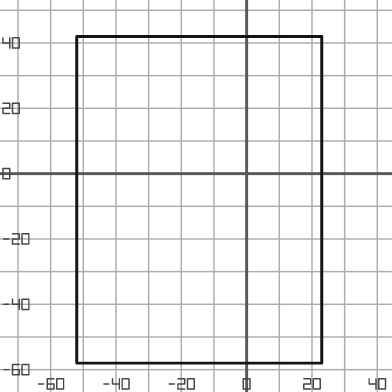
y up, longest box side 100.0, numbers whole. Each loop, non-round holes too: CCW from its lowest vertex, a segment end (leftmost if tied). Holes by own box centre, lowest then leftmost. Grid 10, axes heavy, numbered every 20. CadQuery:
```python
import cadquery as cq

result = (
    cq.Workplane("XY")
    .moveTo(-52.0, -58.0)
    .lineTo(23.0, -58.0)
    .lineTo(23.0, 42.0)
    .lineTo(-52.0, 42.0)
    .close()
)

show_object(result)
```